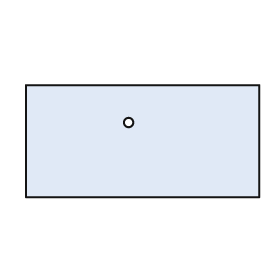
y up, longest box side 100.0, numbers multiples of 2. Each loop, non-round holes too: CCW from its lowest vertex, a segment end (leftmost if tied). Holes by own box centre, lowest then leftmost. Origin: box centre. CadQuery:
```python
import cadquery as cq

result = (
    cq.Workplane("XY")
    .moveTo(-50.0, -24.0)
    .lineTo(50.0, -24.0)
    .lineTo(50.0, 24.0)
    .lineTo(-50.0, 24.0)
    .close()
    .moveTo(-6.0, 8.0)
    .circle(2.0)
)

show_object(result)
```